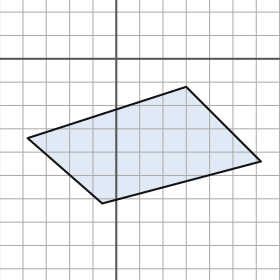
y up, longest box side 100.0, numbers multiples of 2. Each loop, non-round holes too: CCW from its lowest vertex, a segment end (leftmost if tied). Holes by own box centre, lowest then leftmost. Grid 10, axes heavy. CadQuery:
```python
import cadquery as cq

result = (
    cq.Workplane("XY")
    .moveTo(-6.0, -62.0)
    .lineTo(62.0, -44.0)
    .lineTo(30.0, -12.0)
    .lineTo(-38.0, -34.0)
    .close()
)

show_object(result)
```